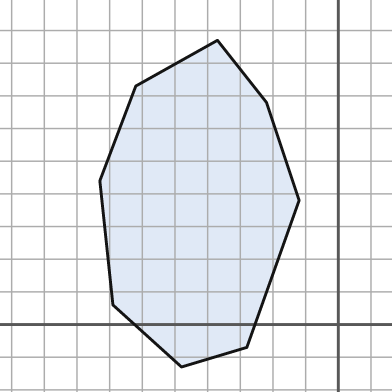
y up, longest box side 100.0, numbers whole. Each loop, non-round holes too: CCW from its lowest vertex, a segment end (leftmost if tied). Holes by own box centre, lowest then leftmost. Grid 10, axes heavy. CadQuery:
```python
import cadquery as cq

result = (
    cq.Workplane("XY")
    .moveTo(-48.0, -13.0)
    .lineTo(-28.0, -7.0)
    .lineTo(-12.0, 38.0)
    .lineTo(-22.0, 68.0)
    .lineTo(-37.0, 87.0)
    .lineTo(-62.0, 73.0)
    .lineTo(-73.0, 44.0)
    .lineTo(-69.0, 6.0)
    .close()
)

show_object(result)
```